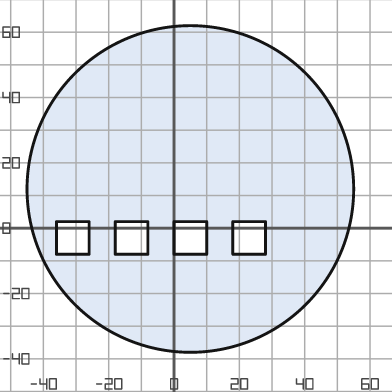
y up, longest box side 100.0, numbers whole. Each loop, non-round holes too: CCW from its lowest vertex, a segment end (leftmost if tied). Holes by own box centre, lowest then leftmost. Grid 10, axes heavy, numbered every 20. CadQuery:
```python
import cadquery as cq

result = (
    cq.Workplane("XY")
    .moveTo(5.0, 12.0)
    .circle(50.0)
    .moveTo(-36.0, -8.0)
    .lineTo(-26.0, -8.0)
    .lineTo(-26.0, 2.0)
    .lineTo(-36.0, 2.0)
    .close()
    .moveTo(-18.0, -8.0)
    .lineTo(-8.0, -8.0)
    .lineTo(-8.0, 2.0)
    .lineTo(-18.0, 2.0)
    .close()
    .moveTo(0.0, -8.0)
    .lineTo(10.0, -8.0)
    .lineTo(10.0, 2.0)
    .lineTo(0.0, 2.0)
    .close()
    .moveTo(18.0, -8.0)
    .lineTo(28.0, -8.0)
    .lineTo(28.0, 2.0)
    .lineTo(18.0, 2.0)
    .close()
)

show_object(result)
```